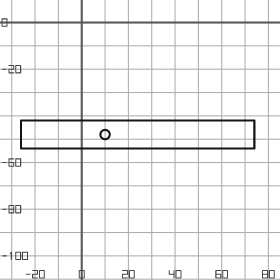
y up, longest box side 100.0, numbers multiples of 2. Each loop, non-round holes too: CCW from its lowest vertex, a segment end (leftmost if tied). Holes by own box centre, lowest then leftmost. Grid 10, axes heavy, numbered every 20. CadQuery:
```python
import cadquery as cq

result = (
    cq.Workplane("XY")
    .moveTo(-26.0, -54.0)
    .lineTo(74.0, -54.0)
    .lineTo(74.0, -42.0)
    .lineTo(-26.0, -42.0)
    .close()
    .moveTo(10.0, -48.0)
    .circle(2.0)
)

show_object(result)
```